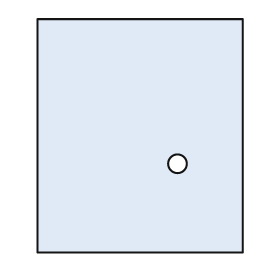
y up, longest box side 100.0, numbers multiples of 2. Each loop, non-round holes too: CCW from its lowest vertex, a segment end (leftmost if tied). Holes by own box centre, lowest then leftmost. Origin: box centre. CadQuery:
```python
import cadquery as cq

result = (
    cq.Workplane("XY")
    .moveTo(-44.0, -50.0)
    .lineTo(44.0, -50.0)
    .lineTo(44.0, 50.0)
    .lineTo(-44.0, 50.0)
    .close()
    .moveTo(16.0, -12.0)
    .circle(4.0)
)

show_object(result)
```